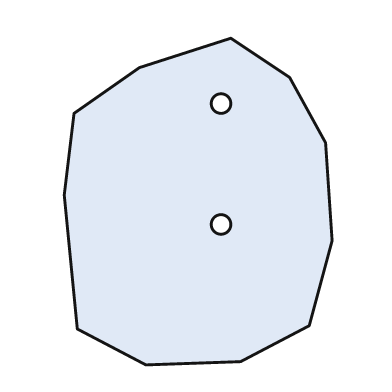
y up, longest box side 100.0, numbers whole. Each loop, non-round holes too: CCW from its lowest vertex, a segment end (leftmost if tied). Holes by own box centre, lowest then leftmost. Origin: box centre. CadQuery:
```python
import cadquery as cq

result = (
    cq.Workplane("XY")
    .moveTo(-16.0, -50.0)
    .lineTo(13.0, -49.0)
    .lineTo(34.0, -38.0)
    .lineTo(41.0, -12.0)
    .lineTo(39.0, 18.0)
    .lineTo(28.0, 38.0)
    .lineTo(10.0, 50.0)
    .lineTo(-18.0, 41.0)
    .lineTo(-38.0, 27.0)
    .lineTo(-41.0, 2.0)
    .lineTo(-37.0, -39.0)
    .close()
    .moveTo(7.0, -7.0)
    .circle(3.0)
    .moveTo(7.0, 30.0)
    .circle(3.0)
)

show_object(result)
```